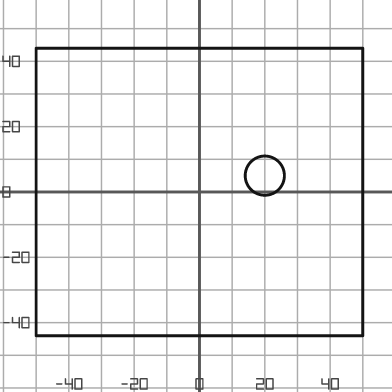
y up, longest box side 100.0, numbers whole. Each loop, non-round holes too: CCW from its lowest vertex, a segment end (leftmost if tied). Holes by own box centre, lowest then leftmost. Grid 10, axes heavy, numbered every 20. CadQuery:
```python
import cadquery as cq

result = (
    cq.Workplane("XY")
    .moveTo(-50.0, -44.0)
    .lineTo(50.0, -44.0)
    .lineTo(50.0, 44.0)
    .lineTo(-50.0, 44.0)
    .close()
    .moveTo(20.0, 5.0)
    .circle(6.0)
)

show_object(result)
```